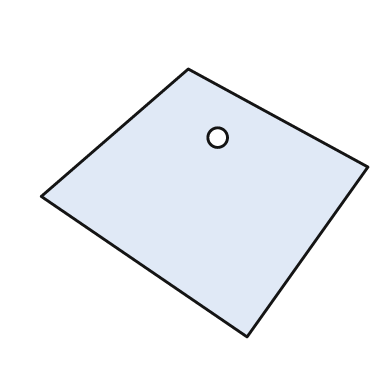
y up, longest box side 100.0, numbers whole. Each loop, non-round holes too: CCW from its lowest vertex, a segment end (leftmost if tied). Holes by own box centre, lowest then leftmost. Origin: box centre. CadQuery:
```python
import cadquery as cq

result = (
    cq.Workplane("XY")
    .moveTo(13.0, -41.0)
    .lineTo(50.0, 11.0)
    .lineTo(-5.0, 41.0)
    .lineTo(-50.0, 2.0)
    .close()
    .moveTo(4.0, 20.0)
    .circle(3.0)
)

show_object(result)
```